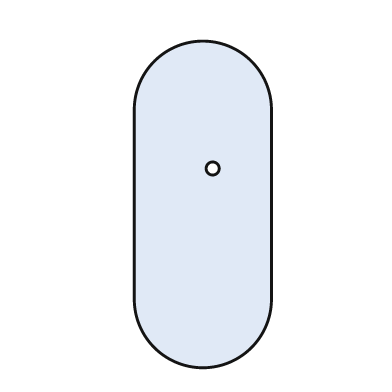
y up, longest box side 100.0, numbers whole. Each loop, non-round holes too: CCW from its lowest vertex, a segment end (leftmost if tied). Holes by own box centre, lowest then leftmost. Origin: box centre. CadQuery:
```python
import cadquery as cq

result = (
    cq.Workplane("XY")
    .moveTo(-21.0, -29.0)
    .threePointArc((0.0, -50.0), (21.0, -29.0))
    .lineTo(21.0, 29.0)
    .threePointArc((0.0, 50.0), (-21.0, 29.0))
    .close()
    .moveTo(3.0, 11.0)
    .circle(2.0)
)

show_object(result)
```